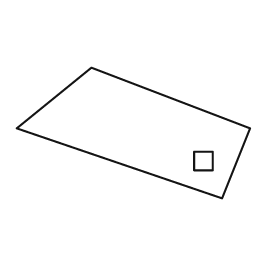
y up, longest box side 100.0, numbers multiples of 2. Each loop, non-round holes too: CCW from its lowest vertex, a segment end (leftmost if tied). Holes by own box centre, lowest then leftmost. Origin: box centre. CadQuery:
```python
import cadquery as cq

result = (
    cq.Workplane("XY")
    .moveTo(38.0, -28.0)
    .lineTo(50.0, 2.0)
    .lineTo(-18.0, 28.0)
    .lineTo(-50.0, 2.0)
    .close()
    .moveTo(26.0, -16.0)
    .lineTo(34.0, -16.0)
    .lineTo(34.0, -8.0)
    .lineTo(26.0, -8.0)
    .close()
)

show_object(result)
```